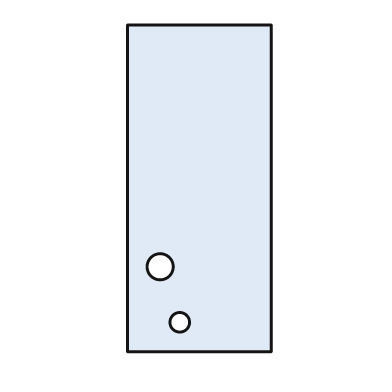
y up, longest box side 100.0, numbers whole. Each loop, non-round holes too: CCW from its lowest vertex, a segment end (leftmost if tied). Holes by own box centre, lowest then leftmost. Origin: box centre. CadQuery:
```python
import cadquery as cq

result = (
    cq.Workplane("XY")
    .moveTo(-22.0, -50.0)
    .lineTo(22.0, -50.0)
    .lineTo(22.0, 50.0)
    .lineTo(-22.0, 50.0)
    .close()
    .moveTo(-6.0, -41.0)
    .circle(3.0)
    .moveTo(-12.0, -24.0)
    .circle(4.0)
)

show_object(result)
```